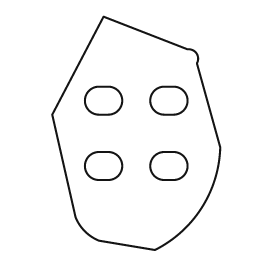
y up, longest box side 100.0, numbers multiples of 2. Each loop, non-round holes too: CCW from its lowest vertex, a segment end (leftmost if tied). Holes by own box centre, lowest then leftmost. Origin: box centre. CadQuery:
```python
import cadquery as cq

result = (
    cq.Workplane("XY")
    .moveTo(8.0, -50.0)
    .threePointArc((28.0, -32.0), (36.0, -6.0))
    .lineTo(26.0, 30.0)
    .threePointArc((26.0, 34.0), (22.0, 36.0))
    .lineTo(-14.0, 50.0)
    .lineTo(-36.0, 8.0)
    .lineTo(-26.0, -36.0)
    .threePointArc((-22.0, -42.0), (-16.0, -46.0))
    .close()
    .moveTo(-16.0, -20.0)
    .lineTo(-12.0, -20.0)
    .threePointArc((-6.0, -14.0), (-12.0, -8.0))
    .lineTo(-16.0, -8.0)
    .threePointArc((-22.0, -14.0), (-16.0, -20.0))
    .close()
    .moveTo(12.0, -20.0)
    .lineTo(16.0, -20.0)
    .threePointArc((22.0, -14.0), (16.0, -8.0))
    .lineTo(12.0, -8.0)
    .threePointArc((6.0, -14.0), (12.0, -20.0))
    .close()
    .moveTo(-16.0, 8.0)
    .lineTo(-12.0, 8.0)
    .threePointArc((-6.0, 14.0), (-12.0, 20.0))
    .lineTo(-16.0, 20.0)
    .threePointArc((-22.0, 14.0), (-16.0, 8.0))
    .close()
    .moveTo(12.0, 8.0)
    .lineTo(16.0, 8.0)
    .threePointArc((22.0, 14.0), (16.0, 20.0))
    .lineTo(12.0, 20.0)
    .threePointArc((6.0, 14.0), (12.0, 8.0))
    .close()
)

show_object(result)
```